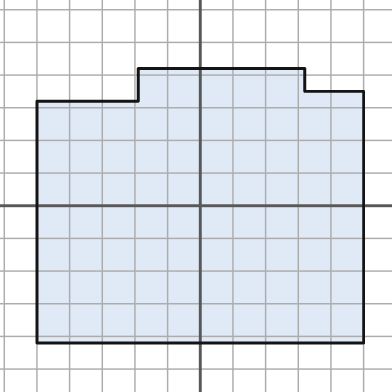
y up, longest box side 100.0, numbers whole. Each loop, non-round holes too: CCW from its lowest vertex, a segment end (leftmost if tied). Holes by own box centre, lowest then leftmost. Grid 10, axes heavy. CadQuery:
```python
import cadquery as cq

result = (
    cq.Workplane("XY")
    .moveTo(-50.0, -42.0)
    .lineTo(50.0, -42.0)
    .lineTo(50.0, 35.0)
    .lineTo(32.0, 35.0)
    .lineTo(32.0, 42.0)
    .lineTo(-19.0, 42.0)
    .lineTo(-19.0, 32.0)
    .lineTo(-50.0, 32.0)
    .close()
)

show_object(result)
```